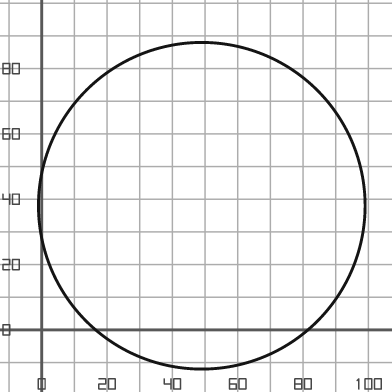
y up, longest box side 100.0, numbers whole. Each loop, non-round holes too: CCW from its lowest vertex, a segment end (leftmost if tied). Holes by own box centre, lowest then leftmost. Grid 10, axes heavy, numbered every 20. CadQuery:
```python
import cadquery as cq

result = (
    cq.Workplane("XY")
    .moveTo(49.0, 38.0)
    .circle(50.0)
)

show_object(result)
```